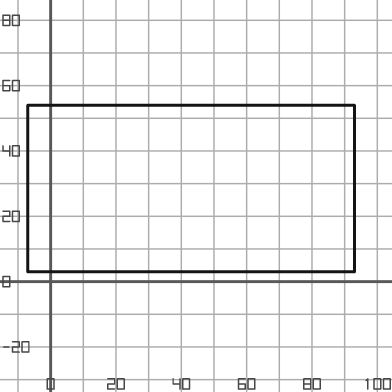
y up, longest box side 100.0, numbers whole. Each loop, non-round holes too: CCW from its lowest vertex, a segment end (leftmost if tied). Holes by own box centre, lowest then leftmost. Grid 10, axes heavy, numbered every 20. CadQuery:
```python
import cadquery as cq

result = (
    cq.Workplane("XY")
    .moveTo(-7.0, 3.0)
    .lineTo(93.0, 3.0)
    .lineTo(93.0, 54.0)
    .lineTo(-7.0, 54.0)
    .close()
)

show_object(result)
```